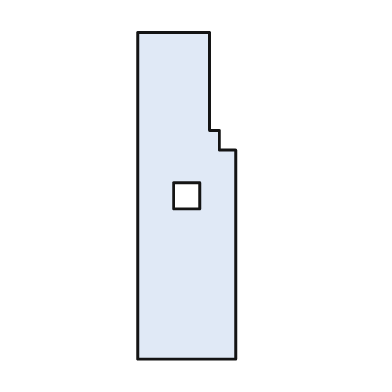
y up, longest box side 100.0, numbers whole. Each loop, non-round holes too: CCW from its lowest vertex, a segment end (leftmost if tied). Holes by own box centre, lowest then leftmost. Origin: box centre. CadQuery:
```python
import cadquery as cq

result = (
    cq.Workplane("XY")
    .moveTo(-15.0, -50.0)
    .lineTo(15.0, -50.0)
    .lineTo(15.0, 14.0)
    .lineTo(10.0, 14.0)
    .lineTo(10.0, 20.0)
    .lineTo(7.0, 20.0)
    .lineTo(7.0, 50.0)
    .lineTo(-15.0, 50.0)
    .close()
    .moveTo(-4.0, -4.0)
    .lineTo(4.0, -4.0)
    .lineTo(4.0, 4.0)
    .lineTo(-4.0, 4.0)
    .close()
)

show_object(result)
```